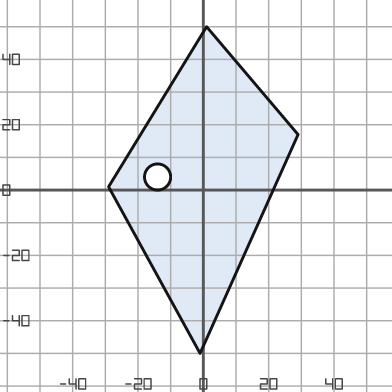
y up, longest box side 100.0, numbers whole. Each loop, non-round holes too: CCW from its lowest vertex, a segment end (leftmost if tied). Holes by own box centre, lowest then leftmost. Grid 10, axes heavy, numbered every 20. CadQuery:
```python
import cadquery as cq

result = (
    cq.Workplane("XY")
    .moveTo(-1.0, -50.0)
    .lineTo(29.0, 17.0)
    .lineTo(1.0, 50.0)
    .lineTo(-29.0, 1.0)
    .close()
    .moveTo(-14.0, 4.0)
    .circle(4.0)
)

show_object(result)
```